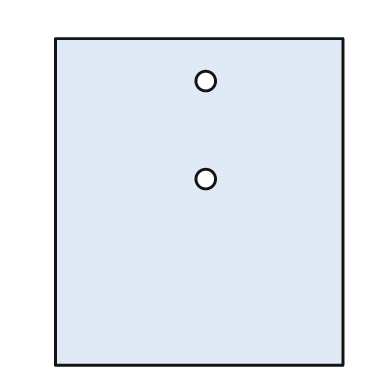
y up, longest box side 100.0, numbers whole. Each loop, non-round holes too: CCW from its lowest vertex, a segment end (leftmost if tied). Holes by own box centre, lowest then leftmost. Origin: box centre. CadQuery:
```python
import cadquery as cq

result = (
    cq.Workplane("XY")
    .moveTo(-44.0, -50.0)
    .lineTo(44.0, -50.0)
    .lineTo(44.0, 50.0)
    .lineTo(-44.0, 50.0)
    .close()
    .moveTo(2.0, 7.0)
    .circle(3.0)
    .moveTo(2.0, 37.0)
    .circle(3.0)
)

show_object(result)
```